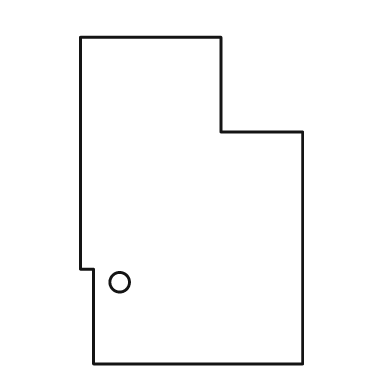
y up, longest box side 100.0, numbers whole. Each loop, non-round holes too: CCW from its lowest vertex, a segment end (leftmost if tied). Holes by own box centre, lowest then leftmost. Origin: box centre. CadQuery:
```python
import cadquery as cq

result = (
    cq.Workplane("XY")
    .moveTo(-30.0, -50.0)
    .lineTo(34.0, -50.0)
    .lineTo(34.0, 21.0)
    .lineTo(9.0, 21.0)
    .lineTo(9.0, 50.0)
    .lineTo(-34.0, 50.0)
    .lineTo(-34.0, -21.0)
    .lineTo(-30.0, -21.0)
    .close()
    .moveTo(-22.0, -25.0)
    .circle(3.0)
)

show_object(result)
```